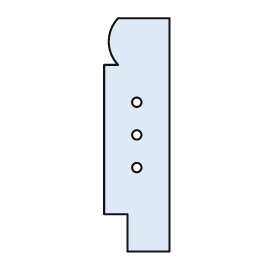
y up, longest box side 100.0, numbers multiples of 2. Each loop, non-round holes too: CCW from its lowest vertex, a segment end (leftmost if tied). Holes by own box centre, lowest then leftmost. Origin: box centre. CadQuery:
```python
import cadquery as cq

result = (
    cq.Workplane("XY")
    .moveTo(-4.0, -50.0)
    .lineTo(14.0, -50.0)
    .lineTo(14.0, 50.0)
    .lineTo(-8.0, 50.0)
    .threePointArc((-12.0, 40.0), (-8.0, 30.0))
    .lineTo(-14.0, 30.0)
    .lineTo(-14.0, -34.0)
    .lineTo(-4.0, -34.0)
    .close()
    .moveTo(0.0, -14.0)
    .circle(2.0)
    .moveTo(0.0, 0.0)
    .circle(2.0)
    .moveTo(0.0, 14.0)
    .circle(2.0)
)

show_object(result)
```